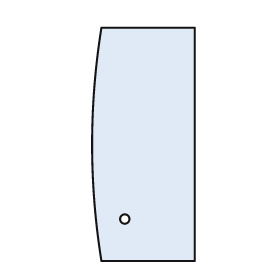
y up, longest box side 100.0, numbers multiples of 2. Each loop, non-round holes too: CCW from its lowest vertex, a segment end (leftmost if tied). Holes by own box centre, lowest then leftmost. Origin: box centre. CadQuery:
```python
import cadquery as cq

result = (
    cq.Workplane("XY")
    .moveTo(-18.0, -50.0)
    .lineTo(22.0, -50.0)
    .lineTo(22.0, 50.0)
    .lineTo(-18.0, 50.0)
    .threePointArc((-22.0, 0.0), (-18.0, -50.0))
    .close()
    .moveTo(-8.0, -32.0)
    .circle(2.0)
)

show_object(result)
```